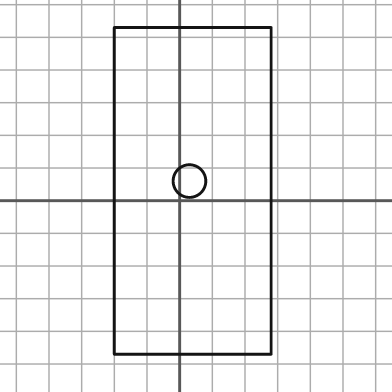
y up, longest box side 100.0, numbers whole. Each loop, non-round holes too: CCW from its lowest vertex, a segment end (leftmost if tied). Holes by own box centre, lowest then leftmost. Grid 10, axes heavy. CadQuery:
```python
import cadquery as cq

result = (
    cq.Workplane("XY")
    .moveTo(-20.0, -47.0)
    .lineTo(28.0, -47.0)
    .lineTo(28.0, 53.0)
    .lineTo(-20.0, 53.0)
    .close()
    .moveTo(3.0, 6.0)
    .circle(5.0)
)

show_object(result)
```